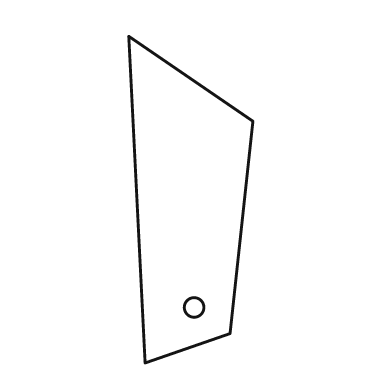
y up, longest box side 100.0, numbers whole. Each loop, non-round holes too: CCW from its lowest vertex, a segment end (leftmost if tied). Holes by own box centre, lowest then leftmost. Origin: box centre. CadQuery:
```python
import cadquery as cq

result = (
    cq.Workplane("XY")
    .moveTo(-14.0, -50.0)
    .lineTo(12.0, -41.0)
    .lineTo(19.0, 24.0)
    .lineTo(-19.0, 50.0)
    .close()
    .moveTo(1.0, -33.0)
    .circle(3.0)
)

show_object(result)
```